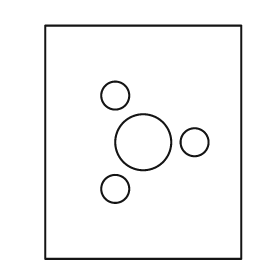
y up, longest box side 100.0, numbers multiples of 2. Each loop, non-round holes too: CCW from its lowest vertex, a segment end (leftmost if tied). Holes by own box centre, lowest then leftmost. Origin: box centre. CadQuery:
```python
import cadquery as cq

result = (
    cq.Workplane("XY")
    .moveTo(-42.0, -50.0)
    .lineTo(42.0, -50.0)
    .lineTo(42.0, 50.0)
    .lineTo(-42.0, 50.0)
    .close()
    .moveTo(-12.0, -20.0)
    .circle(6.0)
    .moveTo(0.0, 0.0)
    .circle(12.0)
    .moveTo(22.0, 0.0)
    .circle(6.0)
    .moveTo(-12.0, 20.0)
    .circle(6.0)
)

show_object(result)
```